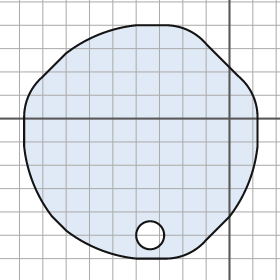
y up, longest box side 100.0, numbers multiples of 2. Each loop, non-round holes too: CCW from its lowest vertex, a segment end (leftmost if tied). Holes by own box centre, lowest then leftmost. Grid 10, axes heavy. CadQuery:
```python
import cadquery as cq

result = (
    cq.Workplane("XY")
    .moveTo(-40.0, -60.0)
    .lineTo(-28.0, -60.0)
    .threePointArc((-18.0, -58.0), (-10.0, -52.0))
    .lineTo(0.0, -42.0)
    .threePointArc((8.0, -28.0), (12.0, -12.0))
    .lineTo(12.0, 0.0)
    .threePointArc((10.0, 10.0), (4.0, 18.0))
    .lineTo(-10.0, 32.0)
    .threePointArc((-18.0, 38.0), (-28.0, 40.0))
    .lineTo(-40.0, 40.0)
    .threePointArc((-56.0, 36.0), (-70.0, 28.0))
    .lineTo(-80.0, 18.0)
    .threePointArc((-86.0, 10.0), (-88.0, 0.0))
    .lineTo(-88.0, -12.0)
    .threePointArc((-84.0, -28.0), (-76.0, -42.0))
    .lineTo(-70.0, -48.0)
    .threePointArc((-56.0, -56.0), (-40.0, -60.0))
    .close()
    .moveTo(-34.0, -50.0)
    .circle(6.0)
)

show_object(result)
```